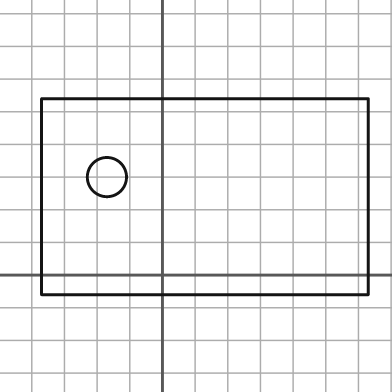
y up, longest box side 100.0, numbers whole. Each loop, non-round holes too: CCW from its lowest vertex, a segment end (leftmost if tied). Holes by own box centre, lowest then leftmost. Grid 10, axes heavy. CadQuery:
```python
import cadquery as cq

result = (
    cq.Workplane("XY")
    .moveTo(-37.0, -6.0)
    .lineTo(63.0, -6.0)
    .lineTo(63.0, 54.0)
    .lineTo(-37.0, 54.0)
    .close()
    .moveTo(-17.0, 30.0)
    .circle(6.0)
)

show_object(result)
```